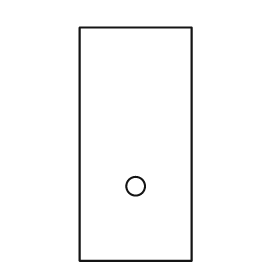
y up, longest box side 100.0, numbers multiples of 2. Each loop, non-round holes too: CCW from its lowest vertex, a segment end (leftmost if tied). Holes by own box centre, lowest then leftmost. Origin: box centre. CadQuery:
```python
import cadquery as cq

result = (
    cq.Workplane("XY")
    .moveTo(-24.0, -50.0)
    .lineTo(24.0, -50.0)
    .lineTo(24.0, 50.0)
    .lineTo(-24.0, 50.0)
    .close()
    .moveTo(0.0, -18.0)
    .circle(4.0)
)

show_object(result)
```